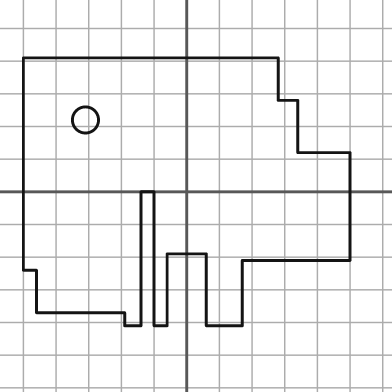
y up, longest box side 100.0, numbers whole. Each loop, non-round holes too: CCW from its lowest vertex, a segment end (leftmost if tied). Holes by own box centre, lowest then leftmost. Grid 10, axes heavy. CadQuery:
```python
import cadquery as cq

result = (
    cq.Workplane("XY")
    .moveTo(-19.0, -41.0)
    .lineTo(-14.0, -41.0)
    .lineTo(-14.0, 0.0)
    .lineTo(-10.0, 0.0)
    .lineTo(-10.0, -41.0)
    .lineTo(-6.0, -41.0)
    .lineTo(-6.0, -19.0)
    .lineTo(6.0, -19.0)
    .lineTo(6.0, -41.0)
    .lineTo(17.0, -41.0)
    .lineTo(17.0, -21.0)
    .lineTo(50.0, -21.0)
    .lineTo(50.0, 12.0)
    .lineTo(34.0, 12.0)
    .lineTo(34.0, 28.0)
    .lineTo(28.0, 28.0)
    .lineTo(28.0, 41.0)
    .lineTo(-50.0, 41.0)
    .lineTo(-50.0, -24.0)
    .lineTo(-46.0, -24.0)
    .lineTo(-46.0, -37.0)
    .lineTo(-19.0, -37.0)
    .close()
    .moveTo(-31.0, 22.0)
    .circle(4.0)
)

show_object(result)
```